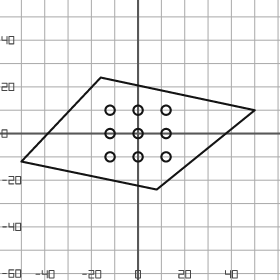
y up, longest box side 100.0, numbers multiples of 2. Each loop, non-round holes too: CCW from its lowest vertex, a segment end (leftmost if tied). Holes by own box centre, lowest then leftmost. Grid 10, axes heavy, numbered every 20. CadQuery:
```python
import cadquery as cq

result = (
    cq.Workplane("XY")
    .moveTo(8.0, -24.0)
    .lineTo(50.0, 10.0)
    .lineTo(-16.0, 24.0)
    .lineTo(-50.0, -12.0)
    .close()
    .moveTo(-12.0, -10.0)
    .circle(2.0)
    .moveTo(0.0, -10.0)
    .circle(2.0)
    .moveTo(12.0, -10.0)
    .circle(2.0)
    .moveTo(-12.0, 0.0)
    .circle(2.0)
    .moveTo(0.0, 0.0)
    .circle(2.0)
    .moveTo(12.0, 0.0)
    .circle(2.0)
    .moveTo(-12.0, 10.0)
    .circle(2.0)
    .moveTo(0.0, 10.0)
    .circle(2.0)
    .moveTo(12.0, 10.0)
    .circle(2.0)
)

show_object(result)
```